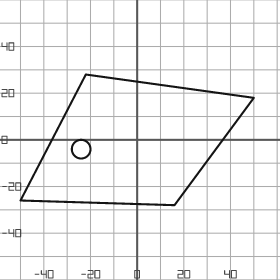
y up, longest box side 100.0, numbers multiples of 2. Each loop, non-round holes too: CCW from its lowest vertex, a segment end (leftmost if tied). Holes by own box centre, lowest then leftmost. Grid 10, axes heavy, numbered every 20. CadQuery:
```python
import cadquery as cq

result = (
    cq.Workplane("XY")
    .moveTo(16.0, -28.0)
    .lineTo(50.0, 18.0)
    .lineTo(-22.0, 28.0)
    .lineTo(-50.0, -26.0)
    .close()
    .moveTo(-24.0, -4.0)
    .circle(4.0)
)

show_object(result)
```